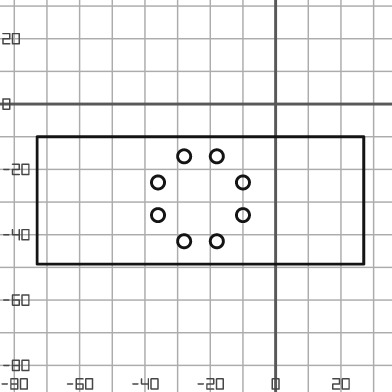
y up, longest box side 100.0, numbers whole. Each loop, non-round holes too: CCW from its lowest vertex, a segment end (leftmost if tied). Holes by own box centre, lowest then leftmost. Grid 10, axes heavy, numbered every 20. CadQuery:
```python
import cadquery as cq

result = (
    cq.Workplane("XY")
    .moveTo(-73.0, -49.0)
    .lineTo(27.0, -49.0)
    .lineTo(27.0, -10.0)
    .lineTo(-73.0, -10.0)
    .close()
    .moveTo(-28.0, -42.0)
    .circle(2.0)
    .moveTo(-18.0, -42.0)
    .circle(2.0)
    .moveTo(-36.0, -34.0)
    .circle(2.0)
    .moveTo(-10.0, -34.0)
    .circle(2.0)
    .moveTo(-36.0, -24.0)
    .circle(2.0)
    .moveTo(-10.0, -24.0)
    .circle(2.0)
    .moveTo(-28.0, -16.0)
    .circle(2.0)
    .moveTo(-18.0, -16.0)
    .circle(2.0)
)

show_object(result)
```